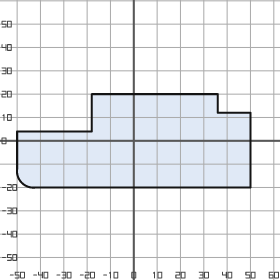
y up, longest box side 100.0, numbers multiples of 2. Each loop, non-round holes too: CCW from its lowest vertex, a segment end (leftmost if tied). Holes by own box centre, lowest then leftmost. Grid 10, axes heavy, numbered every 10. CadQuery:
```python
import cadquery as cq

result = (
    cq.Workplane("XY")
    .moveTo(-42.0, -20.0)
    .lineTo(50.0, -20.0)
    .lineTo(50.0, 12.0)
    .lineTo(36.0, 12.0)
    .lineTo(36.0, 20.0)
    .lineTo(-18.0, 20.0)
    .lineTo(-18.0, 4.0)
    .lineTo(-50.0, 4.0)
    .lineTo(-50.0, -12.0)
    .threePointArc((-48.0, -18.0), (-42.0, -20.0))
    .close()
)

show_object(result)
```